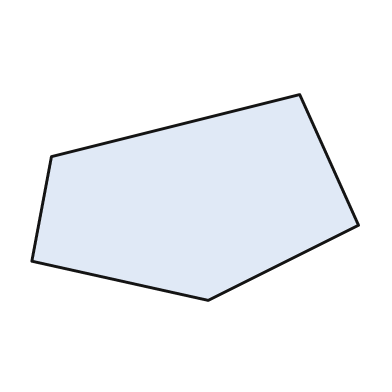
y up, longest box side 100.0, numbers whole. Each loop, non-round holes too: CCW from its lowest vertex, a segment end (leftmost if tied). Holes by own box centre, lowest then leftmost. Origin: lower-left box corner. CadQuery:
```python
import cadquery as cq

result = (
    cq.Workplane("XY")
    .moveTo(54.0, 0.0)
    .lineTo(100.0, 23.0)
    .lineTo(82.0, 63.0)
    .lineTo(6.0, 44.0)
    .lineTo(0.0, 12.0)
    .close()
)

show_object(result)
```